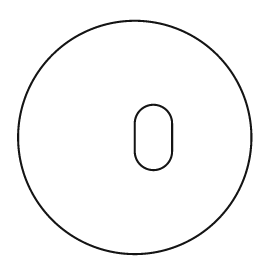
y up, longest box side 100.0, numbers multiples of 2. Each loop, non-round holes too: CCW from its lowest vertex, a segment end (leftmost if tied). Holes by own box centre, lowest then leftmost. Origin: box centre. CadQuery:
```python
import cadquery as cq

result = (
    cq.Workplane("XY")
    .moveTo(0.0, 0.0)
    .circle(50.0)
    .moveTo(0.0, -6.0)
    .threePointArc((8.0, -14.0), (16.0, -6.0))
    .lineTo(16.0, 6.0)
    .threePointArc((8.0, 14.0), (0.0, 6.0))
    .close()
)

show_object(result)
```